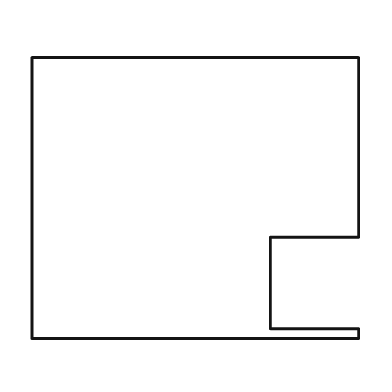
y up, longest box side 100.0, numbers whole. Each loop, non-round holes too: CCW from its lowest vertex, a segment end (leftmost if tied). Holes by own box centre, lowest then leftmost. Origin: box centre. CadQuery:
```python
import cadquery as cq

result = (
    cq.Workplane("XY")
    .moveTo(-50.0, -43.0)
    .lineTo(50.0, -43.0)
    .lineTo(50.0, -40.0)
    .lineTo(23.0, -40.0)
    .lineTo(23.0, -12.0)
    .lineTo(50.0, -12.0)
    .lineTo(50.0, 43.0)
    .lineTo(-50.0, 43.0)
    .close()
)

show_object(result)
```